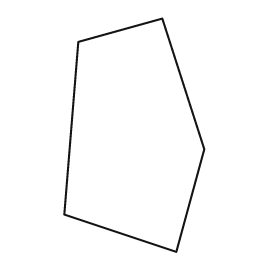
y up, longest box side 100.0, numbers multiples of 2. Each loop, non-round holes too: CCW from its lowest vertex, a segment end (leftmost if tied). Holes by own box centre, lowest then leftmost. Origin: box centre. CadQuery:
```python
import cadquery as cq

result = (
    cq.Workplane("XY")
    .moveTo(18.0, -50.0)
    .lineTo(30.0, -6.0)
    .lineTo(12.0, 50.0)
    .lineTo(-24.0, 40.0)
    .lineTo(-30.0, -34.0)
    .close()
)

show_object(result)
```